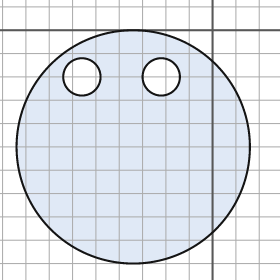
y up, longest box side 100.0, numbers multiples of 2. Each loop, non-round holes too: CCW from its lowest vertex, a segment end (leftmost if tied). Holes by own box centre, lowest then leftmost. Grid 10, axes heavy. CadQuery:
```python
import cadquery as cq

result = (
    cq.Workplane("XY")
    .moveTo(-34.0, -50.0)
    .circle(50.0)
    .moveTo(-56.0, -20.0)
    .circle(8.0)
    .moveTo(-22.0, -20.0)
    .circle(8.0)
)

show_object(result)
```